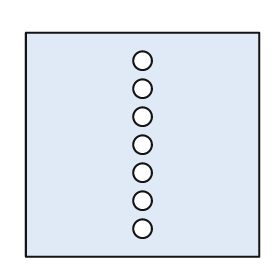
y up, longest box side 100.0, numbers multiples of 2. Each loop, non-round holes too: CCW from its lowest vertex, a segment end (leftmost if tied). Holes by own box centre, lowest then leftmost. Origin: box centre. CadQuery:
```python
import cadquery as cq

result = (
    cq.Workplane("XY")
    .moveTo(-50.0, -48.0)
    .lineTo(50.0, -48.0)
    .lineTo(50.0, 48.0)
    .lineTo(-50.0, 48.0)
    .close()
    .moveTo(0.0, -36.0)
    .circle(4.0)
    .moveTo(0.0, -24.0)
    .circle(4.0)
    .moveTo(0.0, -12.0)
    .circle(4.0)
    .moveTo(0.0, 0.0)
    .circle(4.0)
    .moveTo(0.0, 12.0)
    .circle(4.0)
    .moveTo(0.0, 24.0)
    .circle(4.0)
    .moveTo(0.0, 36.0)
    .circle(4.0)
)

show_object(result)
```